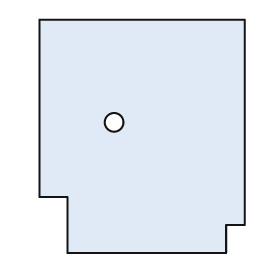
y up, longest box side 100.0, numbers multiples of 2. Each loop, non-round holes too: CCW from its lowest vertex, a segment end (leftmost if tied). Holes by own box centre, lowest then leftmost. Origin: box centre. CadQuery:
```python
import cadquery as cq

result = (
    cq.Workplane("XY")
    .moveTo(-32.0, -50.0)
    .lineTo(36.0, -50.0)
    .lineTo(36.0, -38.0)
    .lineTo(44.0, -38.0)
    .lineTo(44.0, 50.0)
    .lineTo(-44.0, 50.0)
    .lineTo(-44.0, -26.0)
    .lineTo(-32.0, -26.0)
    .close()
    .moveTo(-12.0, 6.0)
    .circle(4.0)
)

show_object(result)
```